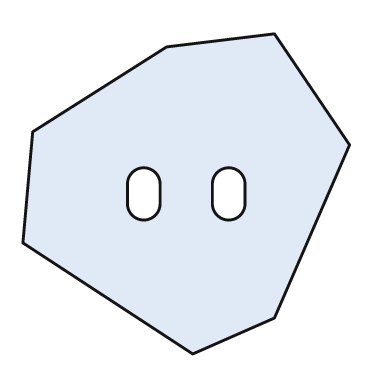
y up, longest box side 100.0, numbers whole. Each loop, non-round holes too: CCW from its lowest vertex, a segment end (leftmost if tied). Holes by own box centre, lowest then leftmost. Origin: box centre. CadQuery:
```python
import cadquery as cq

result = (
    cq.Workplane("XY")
    .moveTo(2.0, -49.0)
    .lineTo(27.0, -38.0)
    .lineTo(50.0, 15.0)
    .lineTo(27.0, 49.0)
    .lineTo(-6.0, 45.0)
    .lineTo(-47.0, 19.0)
    .lineTo(-50.0, -15.0)
    .close()
    .moveTo(-18.0, -3.0)
    .threePointArc((-13.0, -8.0), (-8.0, -3.0))
    .lineTo(-8.0, 3.0)
    .threePointArc((-13.0, 8.0), (-18.0, 3.0))
    .close()
    .moveTo(8.0, -3.0)
    .threePointArc((13.0, -8.0), (18.0, -3.0))
    .lineTo(18.0, 3.0)
    .threePointArc((13.0, 8.0), (8.0, 3.0))
    .close()
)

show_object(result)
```